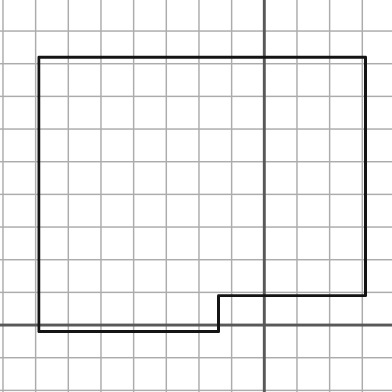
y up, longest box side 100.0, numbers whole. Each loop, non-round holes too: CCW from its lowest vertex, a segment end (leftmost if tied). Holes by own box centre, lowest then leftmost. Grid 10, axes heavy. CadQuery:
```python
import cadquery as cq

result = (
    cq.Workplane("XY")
    .moveTo(-69.0, -2.0)
    .lineTo(-14.0, -2.0)
    .lineTo(-14.0, 9.0)
    .lineTo(31.0, 9.0)
    .lineTo(31.0, 82.0)
    .lineTo(-69.0, 82.0)
    .close()
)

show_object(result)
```